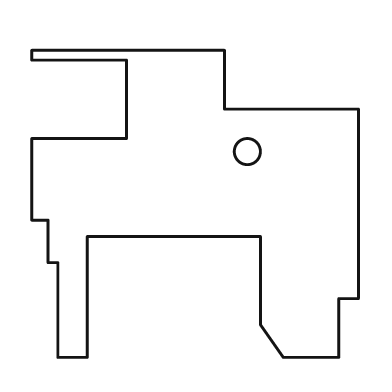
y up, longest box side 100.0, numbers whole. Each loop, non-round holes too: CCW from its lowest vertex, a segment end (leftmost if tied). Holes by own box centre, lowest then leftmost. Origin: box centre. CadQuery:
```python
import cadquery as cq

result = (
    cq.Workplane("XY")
    .moveTo(-42.0, -47.0)
    .lineTo(-33.0, -47.0)
    .lineTo(-33.0, -10.0)
    .lineTo(20.0, -10.0)
    .lineTo(20.0, -37.0)
    .lineTo(27.0, -47.0)
    .lineTo(44.0, -47.0)
    .lineTo(44.0, -29.0)
    .lineTo(50.0, -29.0)
    .lineTo(50.0, 29.0)
    .lineTo(9.0, 29.0)
    .lineTo(9.0, 47.0)
    .lineTo(-50.0, 47.0)
    .lineTo(-50.0, 44.0)
    .lineTo(-21.0, 44.0)
    .lineTo(-21.0, 20.0)
    .lineTo(-50.0, 20.0)
    .lineTo(-50.0, -5.0)
    .lineTo(-45.0, -5.0)
    .lineTo(-45.0, -18.0)
    .lineTo(-42.0, -18.0)
    .close()
    .moveTo(16.0, 16.0)
    .circle(4.0)
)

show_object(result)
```